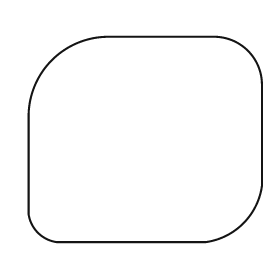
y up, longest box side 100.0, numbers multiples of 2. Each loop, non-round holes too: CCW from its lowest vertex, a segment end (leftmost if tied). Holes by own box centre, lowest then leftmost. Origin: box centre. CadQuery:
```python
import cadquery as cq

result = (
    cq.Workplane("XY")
    .moveTo(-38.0, -44.0)
    .lineTo(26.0, -44.0)
    .threePointArc((42.0, -36.0), (50.0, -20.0))
    .lineTo(50.0, 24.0)
    .threePointArc((44.0, 38.0), (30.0, 44.0))
    .lineTo(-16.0, 44.0)
    .threePointArc((-40.0, 34.0), (-50.0, 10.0))
    .lineTo(-50.0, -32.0)
    .threePointArc((-46.0, -40.0), (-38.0, -44.0))
    .close()
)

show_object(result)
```